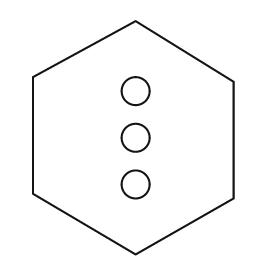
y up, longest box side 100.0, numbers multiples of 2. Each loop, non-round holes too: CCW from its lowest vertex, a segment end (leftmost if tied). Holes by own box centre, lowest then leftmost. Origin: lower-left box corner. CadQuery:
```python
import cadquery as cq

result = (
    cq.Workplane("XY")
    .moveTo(44.0, 0.0)
    .lineTo(86.0, 24.0)
    .lineTo(86.0, 74.0)
    .lineTo(44.0, 100.0)
    .lineTo(0.0, 76.0)
    .lineTo(0.0, 26.0)
    .close()
    .moveTo(44.0, 30.0)
    .circle(6.0)
    .moveTo(44.0, 50.0)
    .circle(6.0)
    .moveTo(44.0, 70.0)
    .circle(6.0)
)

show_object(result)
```